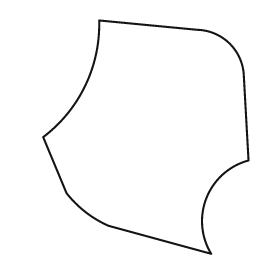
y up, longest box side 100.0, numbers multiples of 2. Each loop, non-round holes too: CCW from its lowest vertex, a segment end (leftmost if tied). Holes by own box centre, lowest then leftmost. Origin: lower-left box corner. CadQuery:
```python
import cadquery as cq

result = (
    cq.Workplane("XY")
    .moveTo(72.0, 0.0)
    .threePointArc((70.0, 24.0), (88.0, 40.0))
    .lineTo(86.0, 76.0)
    .threePointArc((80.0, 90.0), (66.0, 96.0))
    .lineTo(24.0, 100.0)
    .threePointArc((18.0, 72.0), (0.0, 50.0))
    .lineTo(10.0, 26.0)
    .threePointArc((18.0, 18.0), (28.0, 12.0))
    .close()
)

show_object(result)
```